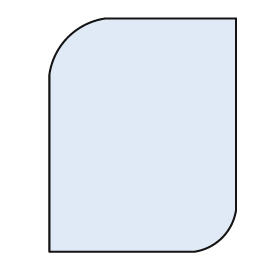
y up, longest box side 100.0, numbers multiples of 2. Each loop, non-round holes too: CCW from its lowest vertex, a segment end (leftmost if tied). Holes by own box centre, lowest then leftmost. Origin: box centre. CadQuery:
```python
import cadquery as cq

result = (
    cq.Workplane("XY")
    .moveTo(-40.0, -50.0)
    .lineTo(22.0, -50.0)
    .threePointArc((34.0, -44.0), (40.0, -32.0))
    .lineTo(40.0, 50.0)
    .lineTo(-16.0, 50.0)
    .threePointArc((-32.0, 42.0), (-40.0, 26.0))
    .close()
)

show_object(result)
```